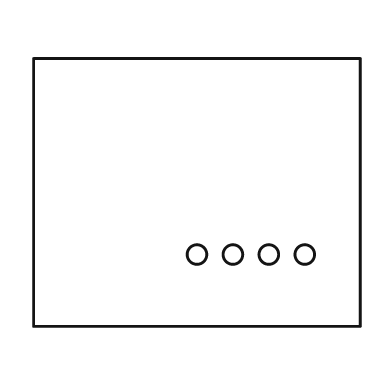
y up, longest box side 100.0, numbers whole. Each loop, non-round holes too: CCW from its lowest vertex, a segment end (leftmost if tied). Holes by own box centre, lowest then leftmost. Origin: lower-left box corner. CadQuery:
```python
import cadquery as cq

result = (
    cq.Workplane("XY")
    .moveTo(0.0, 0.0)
    .lineTo(100.0, 0.0)
    .lineTo(100.0, 82.0)
    .lineTo(0.0, 82.0)
    .close()
    .moveTo(50.0, 22.0)
    .circle(3.0)
    .moveTo(61.0, 22.0)
    .circle(3.0)
    .moveTo(72.0, 22.0)
    .circle(3.0)
    .moveTo(83.0, 22.0)
    .circle(3.0)
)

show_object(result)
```